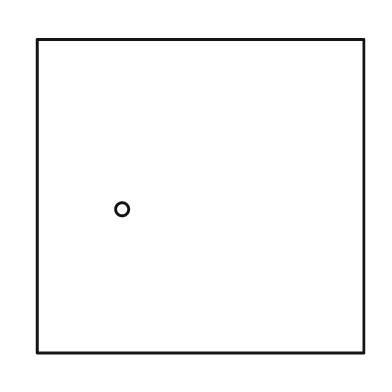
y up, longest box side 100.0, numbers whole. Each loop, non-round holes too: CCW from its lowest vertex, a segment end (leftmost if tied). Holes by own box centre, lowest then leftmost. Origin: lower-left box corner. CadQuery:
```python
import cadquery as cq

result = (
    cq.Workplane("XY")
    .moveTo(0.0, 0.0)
    .lineTo(100.0, 0.0)
    .lineTo(100.0, 96.0)
    .lineTo(0.0, 96.0)
    .close()
    .moveTo(26.0, 44.0)
    .circle(2.0)
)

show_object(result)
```